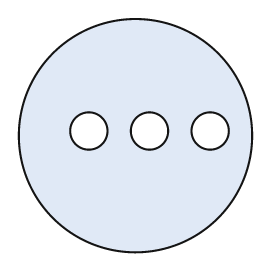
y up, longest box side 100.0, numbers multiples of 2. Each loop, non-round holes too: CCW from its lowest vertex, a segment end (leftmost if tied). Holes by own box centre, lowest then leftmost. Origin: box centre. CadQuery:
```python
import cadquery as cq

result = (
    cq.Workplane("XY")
    .moveTo(0.0, 0.0)
    .circle(50.0)
    .moveTo(-20.0, 2.0)
    .circle(8.0)
    .moveTo(6.0, 2.0)
    .circle(8.0)
    .moveTo(32.0, 2.0)
    .circle(8.0)
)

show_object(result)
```